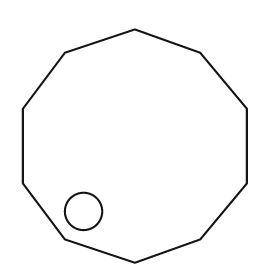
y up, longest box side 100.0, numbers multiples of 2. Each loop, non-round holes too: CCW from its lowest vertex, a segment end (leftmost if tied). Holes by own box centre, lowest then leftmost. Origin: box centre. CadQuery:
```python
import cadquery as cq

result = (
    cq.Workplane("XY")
    .moveTo(0.0, -50.0)
    .lineTo(28.0, -40.0)
    .lineTo(48.0, -16.0)
    .lineTo(48.0, 16.0)
    .lineTo(28.0, 40.0)
    .lineTo(0.0, 50.0)
    .lineTo(-30.0, 40.0)
    .lineTo(-48.0, 16.0)
    .lineTo(-48.0, -16.0)
    .lineTo(-30.0, -40.0)
    .close()
    .moveTo(-22.0, -28.0)
    .circle(8.0)
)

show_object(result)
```